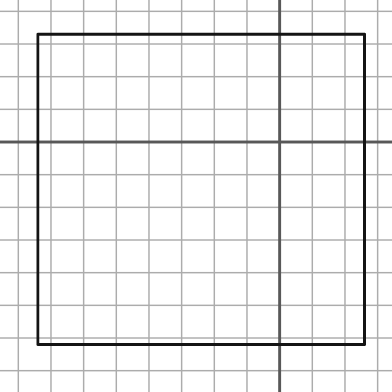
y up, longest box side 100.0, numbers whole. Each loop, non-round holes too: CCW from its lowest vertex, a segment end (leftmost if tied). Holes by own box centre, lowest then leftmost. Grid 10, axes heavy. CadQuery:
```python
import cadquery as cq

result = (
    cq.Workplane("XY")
    .moveTo(-74.0, -62.0)
    .lineTo(26.0, -62.0)
    .lineTo(26.0, 33.0)
    .lineTo(-74.0, 33.0)
    .close()
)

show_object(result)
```